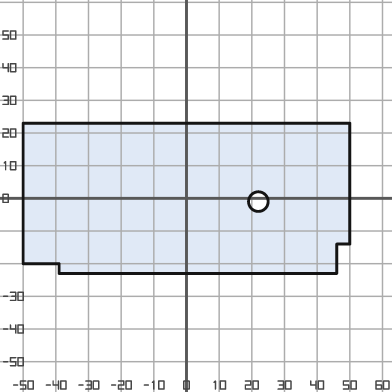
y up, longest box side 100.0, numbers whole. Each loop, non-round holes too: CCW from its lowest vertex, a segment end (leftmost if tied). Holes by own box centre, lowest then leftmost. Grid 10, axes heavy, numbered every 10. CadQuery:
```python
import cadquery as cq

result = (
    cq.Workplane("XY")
    .moveTo(-39.0, -23.0)
    .lineTo(46.0, -23.0)
    .lineTo(46.0, -14.0)
    .lineTo(50.0, -14.0)
    .lineTo(50.0, 23.0)
    .lineTo(-50.0, 23.0)
    .lineTo(-50.0, -20.0)
    .lineTo(-39.0, -20.0)
    .close()
    .moveTo(22.0, -1.0)
    .circle(3.0)
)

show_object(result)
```